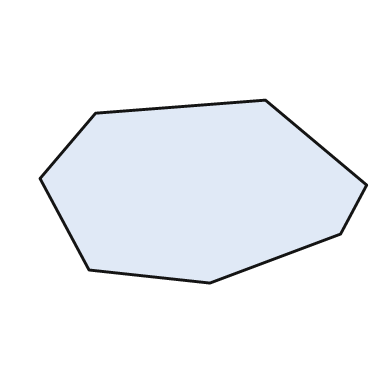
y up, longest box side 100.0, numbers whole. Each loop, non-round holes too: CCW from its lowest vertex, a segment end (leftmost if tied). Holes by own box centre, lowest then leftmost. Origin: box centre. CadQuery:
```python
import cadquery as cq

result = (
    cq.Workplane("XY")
    .moveTo(2.0, -28.0)
    .lineTo(42.0, -13.0)
    .lineTo(50.0, 2.0)
    .lineTo(19.0, 28.0)
    .lineTo(-33.0, 24.0)
    .lineTo(-50.0, 4.0)
    .lineTo(-35.0, -24.0)
    .close()
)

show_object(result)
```